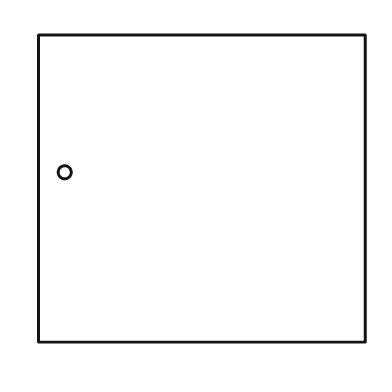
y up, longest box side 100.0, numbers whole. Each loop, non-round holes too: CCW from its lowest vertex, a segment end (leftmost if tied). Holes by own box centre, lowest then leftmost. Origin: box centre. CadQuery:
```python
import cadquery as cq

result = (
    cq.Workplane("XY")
    .moveTo(-50.0, -47.0)
    .lineTo(50.0, -47.0)
    .lineTo(50.0, 47.0)
    .lineTo(-50.0, 47.0)
    .close()
    .moveTo(-42.0, 5.0)
    .circle(2.0)
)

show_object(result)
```